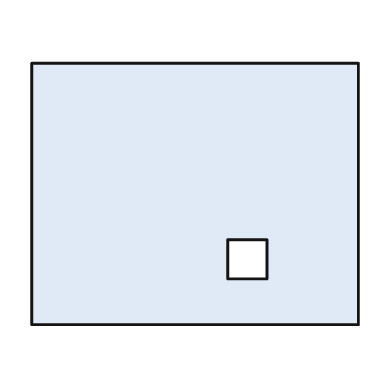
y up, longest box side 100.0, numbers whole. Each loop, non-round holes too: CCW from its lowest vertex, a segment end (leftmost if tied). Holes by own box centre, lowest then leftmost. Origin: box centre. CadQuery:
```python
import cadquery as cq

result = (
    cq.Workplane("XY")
    .moveTo(-50.0, -40.0)
    .lineTo(50.0, -40.0)
    .lineTo(50.0, 40.0)
    .lineTo(-50.0, 40.0)
    .close()
    .moveTo(10.0, -26.0)
    .lineTo(22.0, -26.0)
    .lineTo(22.0, -14.0)
    .lineTo(10.0, -14.0)
    .close()
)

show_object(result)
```